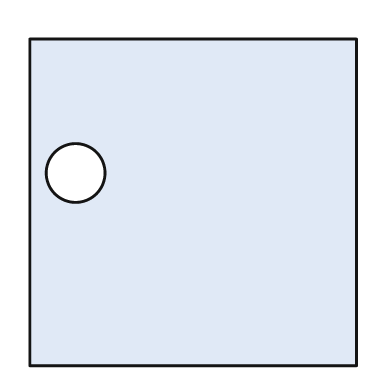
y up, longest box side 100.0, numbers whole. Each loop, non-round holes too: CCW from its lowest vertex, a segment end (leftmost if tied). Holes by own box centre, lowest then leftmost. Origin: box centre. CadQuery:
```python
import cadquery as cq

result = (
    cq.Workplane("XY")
    .moveTo(-50.0, -50.0)
    .lineTo(50.0, -50.0)
    .lineTo(50.0, 50.0)
    .lineTo(-50.0, 50.0)
    .close()
    .moveTo(-36.0, 9.0)
    .circle(9.0)
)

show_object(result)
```